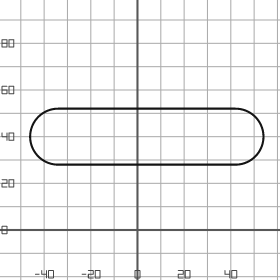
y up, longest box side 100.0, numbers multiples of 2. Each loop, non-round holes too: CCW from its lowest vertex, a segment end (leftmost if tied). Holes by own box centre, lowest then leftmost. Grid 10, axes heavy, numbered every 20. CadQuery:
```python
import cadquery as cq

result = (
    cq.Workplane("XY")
    .moveTo(-34.0, 28.0)
    .lineTo(42.0, 28.0)
    .threePointArc((54.0, 40.0), (42.0, 52.0))
    .lineTo(-34.0, 52.0)
    .threePointArc((-46.0, 40.0), (-34.0, 28.0))
    .close()
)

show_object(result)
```